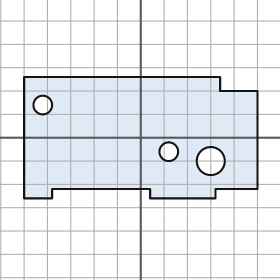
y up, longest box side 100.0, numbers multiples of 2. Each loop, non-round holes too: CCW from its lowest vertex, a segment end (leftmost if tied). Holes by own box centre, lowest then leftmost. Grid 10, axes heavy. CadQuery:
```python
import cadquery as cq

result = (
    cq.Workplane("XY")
    .moveTo(-50.0, -26.0)
    .lineTo(-38.0, -26.0)
    .lineTo(-38.0, -22.0)
    .lineTo(4.0, -22.0)
    .lineTo(4.0, -26.0)
    .lineTo(32.0, -26.0)
    .lineTo(32.0, -22.0)
    .lineTo(50.0, -22.0)
    .lineTo(50.0, 20.0)
    .lineTo(34.0, 20.0)
    .lineTo(34.0, 26.0)
    .lineTo(-50.0, 26.0)
    .close()
    .moveTo(30.0, -10.0)
    .circle(6.0)
    .moveTo(12.0, -6.0)
    .circle(4.0)
    .moveTo(-42.0, 14.0)
    .circle(4.0)
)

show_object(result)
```